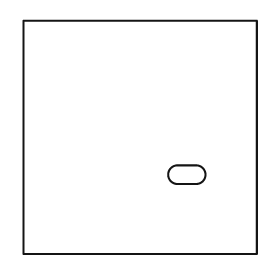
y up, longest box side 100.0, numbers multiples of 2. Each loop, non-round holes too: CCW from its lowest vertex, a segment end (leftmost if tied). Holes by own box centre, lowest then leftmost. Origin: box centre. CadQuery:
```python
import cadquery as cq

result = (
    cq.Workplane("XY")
    .moveTo(-50.0, -50.0)
    .lineTo(50.0, -50.0)
    .lineTo(50.0, 50.0)
    .lineTo(-50.0, 50.0)
    .close()
    .moveTo(16.0, -20.0)
    .lineTo(24.0, -20.0)
    .threePointArc((28.0, -16.0), (24.0, -12.0))
    .lineTo(16.0, -12.0)
    .threePointArc((12.0, -16.0), (16.0, -20.0))
    .close()
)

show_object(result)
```